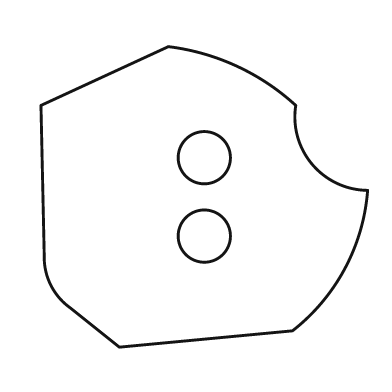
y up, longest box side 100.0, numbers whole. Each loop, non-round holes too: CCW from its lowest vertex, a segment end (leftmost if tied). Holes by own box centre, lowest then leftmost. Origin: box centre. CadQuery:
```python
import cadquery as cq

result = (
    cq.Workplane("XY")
    .moveTo(-26.0, -46.0)
    .lineTo(27.0, -41.0)
    .threePointArc((43.0, -22.0), (50.0, 2.0))
    .threePointArc((33.0, 10.0), (28.0, 28.0))
    .threePointArc((10.0, 40.0), (-11.0, 46.0))
    .lineTo(-50.0, 28.0)
    .lineTo(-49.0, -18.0)
    .threePointArc((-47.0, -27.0), (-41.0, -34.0))
    .close()
    .moveTo(0.0, -12.0)
    .circle(8.0)
    .moveTo(0.0, 12.0)
    .circle(8.0)
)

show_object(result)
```